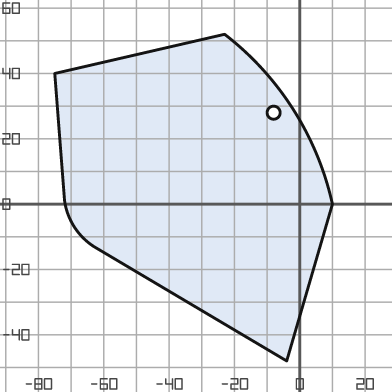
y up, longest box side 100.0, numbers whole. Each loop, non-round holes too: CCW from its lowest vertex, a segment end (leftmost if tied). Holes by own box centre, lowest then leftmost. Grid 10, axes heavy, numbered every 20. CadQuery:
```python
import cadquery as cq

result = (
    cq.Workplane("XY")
    .moveTo(-4.0, -48.0)
    .lineTo(10.0, 0.0)
    .threePointArc((-2.0, 29.0), (-23.0, 52.0))
    .lineTo(-75.0, 40.0)
    .lineTo(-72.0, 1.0)
    .threePointArc((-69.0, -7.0), (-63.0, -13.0))
    .close()
    .moveTo(-8.0, 28.0)
    .circle(2.0)
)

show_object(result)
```